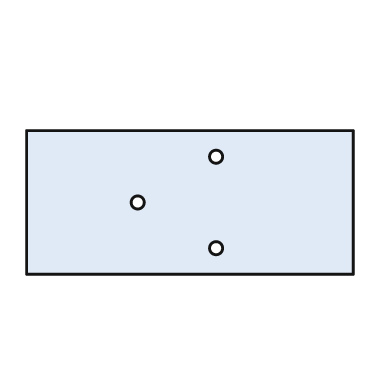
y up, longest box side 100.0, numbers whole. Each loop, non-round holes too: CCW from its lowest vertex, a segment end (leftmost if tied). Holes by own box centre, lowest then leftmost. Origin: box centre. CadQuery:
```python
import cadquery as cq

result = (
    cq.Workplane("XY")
    .moveTo(-50.0, -22.0)
    .lineTo(50.0, -22.0)
    .lineTo(50.0, 22.0)
    .lineTo(-50.0, 22.0)
    .close()
    .moveTo(8.0, -14.0)
    .circle(2.0)
    .moveTo(-16.0, 0.0)
    .circle(2.0)
    .moveTo(8.0, 14.0)
    .circle(2.0)
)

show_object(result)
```